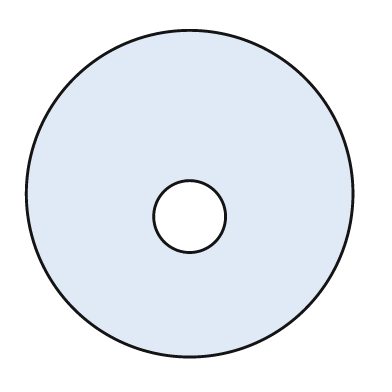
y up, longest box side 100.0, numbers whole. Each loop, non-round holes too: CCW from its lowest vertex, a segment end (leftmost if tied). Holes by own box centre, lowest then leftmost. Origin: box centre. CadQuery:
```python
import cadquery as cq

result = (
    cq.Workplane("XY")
    .moveTo(0.0, 0.0)
    .circle(50.0)
    .moveTo(0.0, -7.0)
    .circle(11.0)
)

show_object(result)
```